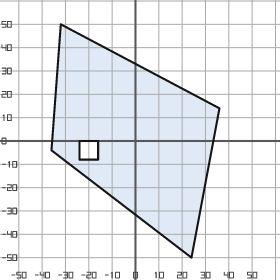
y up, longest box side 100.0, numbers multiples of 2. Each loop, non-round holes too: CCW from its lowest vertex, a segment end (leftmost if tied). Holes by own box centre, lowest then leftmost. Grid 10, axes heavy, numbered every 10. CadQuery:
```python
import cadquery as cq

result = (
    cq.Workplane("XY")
    .moveTo(24.0, -50.0)
    .lineTo(36.0, 14.0)
    .lineTo(-32.0, 50.0)
    .lineTo(-36.0, -4.0)
    .close()
    .moveTo(-24.0, -8.0)
    .lineTo(-16.0, -8.0)
    .lineTo(-16.0, 0.0)
    .lineTo(-24.0, 0.0)
    .close()
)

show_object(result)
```